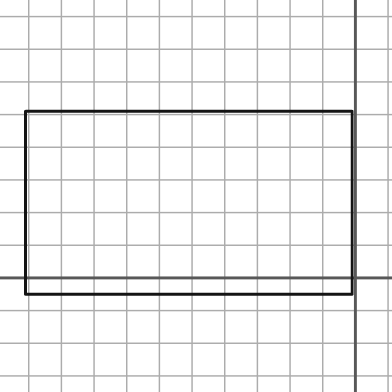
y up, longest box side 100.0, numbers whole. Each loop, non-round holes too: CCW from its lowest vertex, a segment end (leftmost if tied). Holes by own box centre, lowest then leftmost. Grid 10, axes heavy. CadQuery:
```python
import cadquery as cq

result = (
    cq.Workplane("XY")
    .moveTo(-101.0, -5.0)
    .lineTo(-1.0, -5.0)
    .lineTo(-1.0, 51.0)
    .lineTo(-101.0, 51.0)
    .close()
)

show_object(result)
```